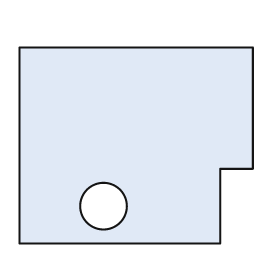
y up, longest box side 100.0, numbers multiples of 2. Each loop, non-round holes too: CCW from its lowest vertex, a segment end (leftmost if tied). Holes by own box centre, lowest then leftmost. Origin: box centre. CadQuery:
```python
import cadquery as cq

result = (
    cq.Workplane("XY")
    .moveTo(-50.0, -42.0)
    .lineTo(36.0, -42.0)
    .lineTo(36.0, -10.0)
    .lineTo(50.0, -10.0)
    .lineTo(50.0, 42.0)
    .lineTo(-50.0, 42.0)
    .close()
    .moveTo(-14.0, -26.0)
    .circle(10.0)
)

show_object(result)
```